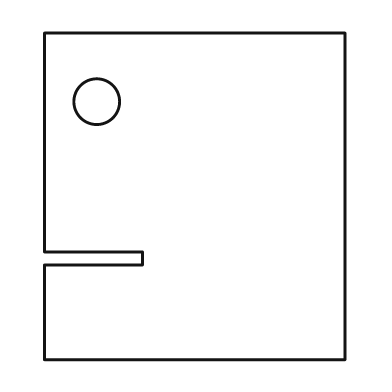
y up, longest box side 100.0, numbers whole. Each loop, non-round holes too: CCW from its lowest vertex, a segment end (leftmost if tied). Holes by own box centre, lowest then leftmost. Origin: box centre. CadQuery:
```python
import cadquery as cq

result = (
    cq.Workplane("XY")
    .moveTo(-46.0, -50.0)
    .lineTo(46.0, -50.0)
    .lineTo(46.0, 50.0)
    .lineTo(-46.0, 50.0)
    .lineTo(-46.0, -17.0)
    .lineTo(-16.0, -17.0)
    .lineTo(-16.0, -21.0)
    .lineTo(-46.0, -21.0)
    .close()
    .moveTo(-30.0, 29.0)
    .circle(7.0)
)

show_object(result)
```